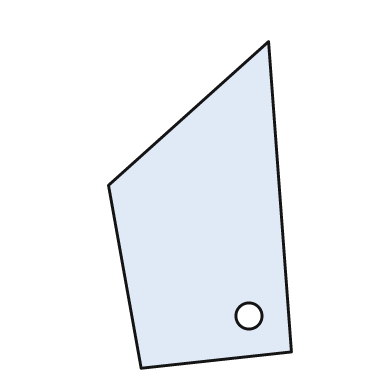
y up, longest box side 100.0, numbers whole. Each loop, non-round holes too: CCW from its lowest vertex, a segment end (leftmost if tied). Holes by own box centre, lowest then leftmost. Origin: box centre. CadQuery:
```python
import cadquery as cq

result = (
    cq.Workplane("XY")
    .moveTo(-18.0, -50.0)
    .lineTo(28.0, -45.0)
    .lineTo(21.0, 50.0)
    .lineTo(-28.0, 6.0)
    .close()
    .moveTo(15.0, -34.0)
    .circle(4.0)
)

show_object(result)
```